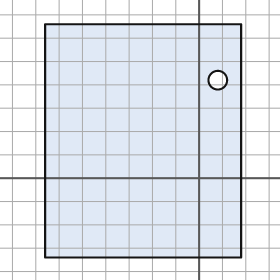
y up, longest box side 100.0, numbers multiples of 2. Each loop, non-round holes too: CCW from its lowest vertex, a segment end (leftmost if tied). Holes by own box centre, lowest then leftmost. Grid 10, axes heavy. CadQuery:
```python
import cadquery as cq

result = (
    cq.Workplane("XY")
    .moveTo(-66.0, -34.0)
    .lineTo(18.0, -34.0)
    .lineTo(18.0, 66.0)
    .lineTo(-66.0, 66.0)
    .close()
    .moveTo(8.0, 42.0)
    .circle(4.0)
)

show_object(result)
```